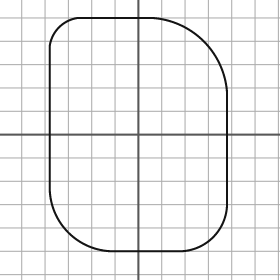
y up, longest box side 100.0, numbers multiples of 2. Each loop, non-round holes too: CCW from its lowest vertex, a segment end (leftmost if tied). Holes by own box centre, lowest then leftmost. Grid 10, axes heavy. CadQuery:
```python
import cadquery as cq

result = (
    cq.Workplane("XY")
    .moveTo(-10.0, -50.0)
    .lineTo(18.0, -50.0)
    .threePointArc((32.0, -44.0), (38.0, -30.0))
    .lineTo(38.0, 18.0)
    .threePointArc((28.0, 40.0), (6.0, 50.0))
    .lineTo(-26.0, 50.0)
    .threePointArc((-34.0, 46.0), (-38.0, 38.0))
    .lineTo(-38.0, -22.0)
    .threePointArc((-30.0, -42.0), (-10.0, -50.0))
    .close()
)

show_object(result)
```